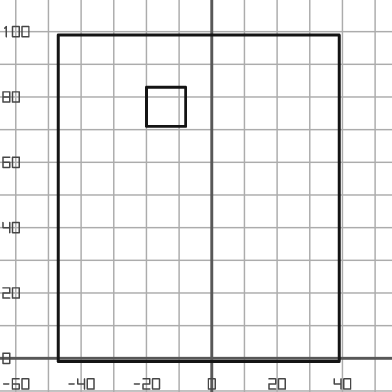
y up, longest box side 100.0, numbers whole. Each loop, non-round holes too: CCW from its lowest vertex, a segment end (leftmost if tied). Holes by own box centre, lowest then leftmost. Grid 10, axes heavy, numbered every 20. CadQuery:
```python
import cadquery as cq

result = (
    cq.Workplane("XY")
    .moveTo(-47.0, -1.0)
    .lineTo(39.0, -1.0)
    .lineTo(39.0, 99.0)
    .lineTo(-47.0, 99.0)
    .close()
    .moveTo(-20.0, 71.0)
    .lineTo(-8.0, 71.0)
    .lineTo(-8.0, 83.0)
    .lineTo(-20.0, 83.0)
    .close()
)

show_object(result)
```